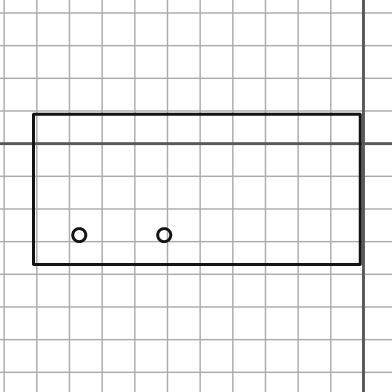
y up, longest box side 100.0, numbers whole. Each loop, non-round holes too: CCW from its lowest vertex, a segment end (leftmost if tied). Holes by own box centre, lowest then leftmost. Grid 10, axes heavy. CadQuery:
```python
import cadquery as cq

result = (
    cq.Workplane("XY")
    .moveTo(-101.0, -37.0)
    .lineTo(-1.0, -37.0)
    .lineTo(-1.0, 9.0)
    .lineTo(-101.0, 9.0)
    .close()
    .moveTo(-87.0, -28.0)
    .circle(2.0)
    .moveTo(-61.0, -28.0)
    .circle(2.0)
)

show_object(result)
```